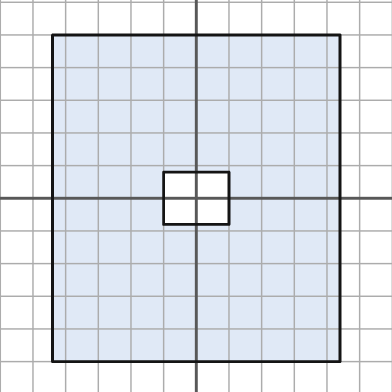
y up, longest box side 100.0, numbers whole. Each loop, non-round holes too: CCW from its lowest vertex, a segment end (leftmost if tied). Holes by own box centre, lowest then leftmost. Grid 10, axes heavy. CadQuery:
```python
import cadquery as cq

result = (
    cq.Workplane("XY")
    .moveTo(-44.0, -50.0)
    .lineTo(44.0, -50.0)
    .lineTo(44.0, 50.0)
    .lineTo(-44.0, 50.0)
    .close()
    .moveTo(-10.0, -8.0)
    .lineTo(10.0, -8.0)
    .lineTo(10.0, 8.0)
    .lineTo(-10.0, 8.0)
    .close()
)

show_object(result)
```